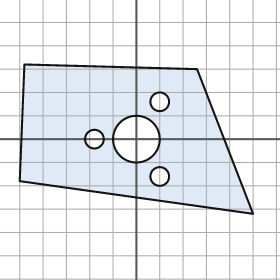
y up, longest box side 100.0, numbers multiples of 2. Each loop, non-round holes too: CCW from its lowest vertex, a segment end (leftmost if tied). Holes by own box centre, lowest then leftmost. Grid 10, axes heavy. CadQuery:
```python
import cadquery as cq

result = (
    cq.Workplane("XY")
    .moveTo(50.0, -32.0)
    .lineTo(26.0, 30.0)
    .lineTo(-48.0, 32.0)
    .lineTo(-50.0, -18.0)
    .close()
    .moveTo(10.0, -16.0)
    .circle(4.0)
    .moveTo(-18.0, 0.0)
    .circle(4.0)
    .moveTo(0.0, 0.0)
    .circle(10.0)
    .moveTo(10.0, 16.0)
    .circle(4.0)
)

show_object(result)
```